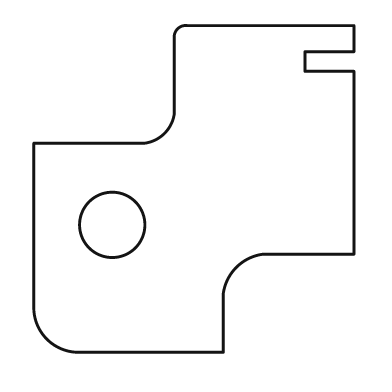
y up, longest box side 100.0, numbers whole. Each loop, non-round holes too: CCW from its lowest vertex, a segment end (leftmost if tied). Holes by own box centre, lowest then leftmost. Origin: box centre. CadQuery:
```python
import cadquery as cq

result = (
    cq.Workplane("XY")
    .moveTo(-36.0, -50.0)
    .lineTo(9.0, -50.0)
    .lineTo(9.0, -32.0)
    .threePointArc((13.0, -24.0), (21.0, -20.0))
    .lineTo(49.0, -20.0)
    .lineTo(49.0, 36.0)
    .lineTo(34.0, 36.0)
    .lineTo(34.0, 42.0)
    .lineTo(49.0, 42.0)
    .lineTo(49.0, 50.0)
    .lineTo(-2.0, 50.0)
    .threePointArc((-5.0, 49.0), (-6.0, 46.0))
    .lineTo(-6.0, 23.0)
    .threePointArc((-9.0, 17.0), (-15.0, 14.0))
    .lineTo(-49.0, 14.0)
    .lineTo(-49.0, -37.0)
    .threePointArc((-45.0, -46.0), (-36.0, -50.0))
    .close()
    .moveTo(-25.0, -11.0)
    .circle(10.0)
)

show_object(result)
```